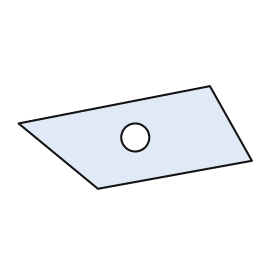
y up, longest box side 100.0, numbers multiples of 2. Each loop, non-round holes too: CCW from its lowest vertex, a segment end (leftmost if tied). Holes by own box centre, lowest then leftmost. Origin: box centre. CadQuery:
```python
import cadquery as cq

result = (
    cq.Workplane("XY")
    .moveTo(-16.0, -22.0)
    .lineTo(50.0, -10.0)
    .lineTo(32.0, 22.0)
    .lineTo(-50.0, 6.0)
    .close()
    .moveTo(0.0, 0.0)
    .circle(6.0)
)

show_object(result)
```